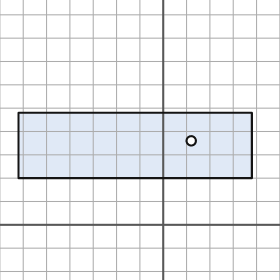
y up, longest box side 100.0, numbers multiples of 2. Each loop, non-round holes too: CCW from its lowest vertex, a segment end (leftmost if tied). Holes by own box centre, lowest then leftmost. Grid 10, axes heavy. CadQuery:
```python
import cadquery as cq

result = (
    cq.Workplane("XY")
    .moveTo(-62.0, 20.0)
    .lineTo(38.0, 20.0)
    .lineTo(38.0, 48.0)
    .lineTo(-62.0, 48.0)
    .close()
    .moveTo(12.0, 36.0)
    .circle(2.0)
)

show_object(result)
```